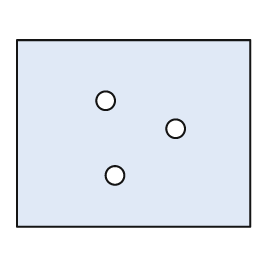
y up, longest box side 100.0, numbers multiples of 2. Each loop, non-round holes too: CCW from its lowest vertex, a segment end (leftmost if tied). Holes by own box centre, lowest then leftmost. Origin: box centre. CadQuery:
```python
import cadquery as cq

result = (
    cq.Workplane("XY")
    .moveTo(-50.0, -40.0)
    .lineTo(50.0, -40.0)
    .lineTo(50.0, 40.0)
    .lineTo(-50.0, 40.0)
    .close()
    .moveTo(-8.0, -18.0)
    .circle(4.0)
    .moveTo(18.0, 2.0)
    .circle(4.0)
    .moveTo(-12.0, 14.0)
    .circle(4.0)
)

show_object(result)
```